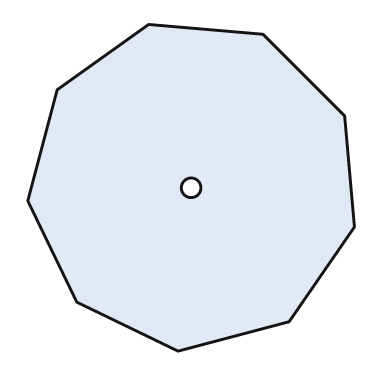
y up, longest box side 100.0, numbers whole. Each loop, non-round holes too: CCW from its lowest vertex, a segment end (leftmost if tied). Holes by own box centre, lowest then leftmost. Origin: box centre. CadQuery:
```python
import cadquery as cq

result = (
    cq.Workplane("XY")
    .moveTo(-4.0, -50.0)
    .lineTo(30.0, -41.0)
    .lineTo(50.0, -12.0)
    .lineTo(47.0, 22.0)
    .lineTo(22.0, 47.0)
    .lineTo(-13.0, 50.0)
    .lineTo(-41.0, 30.0)
    .lineTo(-50.0, -4.0)
    .lineTo(-35.0, -35.0)
    .close()
    .moveTo(0.0, 0.0)
    .circle(3.0)
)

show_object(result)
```